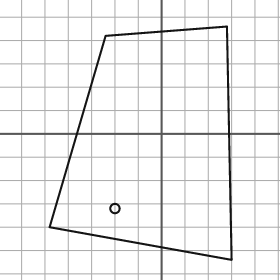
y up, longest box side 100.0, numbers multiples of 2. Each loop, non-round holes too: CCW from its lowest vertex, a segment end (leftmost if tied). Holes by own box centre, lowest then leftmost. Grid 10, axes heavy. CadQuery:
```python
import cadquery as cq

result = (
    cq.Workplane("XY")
    .moveTo(30.0, -54.0)
    .lineTo(28.0, 46.0)
    .lineTo(-24.0, 42.0)
    .lineTo(-48.0, -40.0)
    .close()
    .moveTo(-20.0, -32.0)
    .circle(2.0)
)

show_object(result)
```